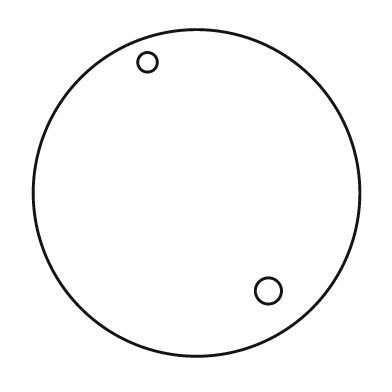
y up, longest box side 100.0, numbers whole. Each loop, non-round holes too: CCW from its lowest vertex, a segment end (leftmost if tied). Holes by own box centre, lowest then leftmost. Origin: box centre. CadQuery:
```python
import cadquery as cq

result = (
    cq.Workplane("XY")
    .moveTo(0.0, 0.0)
    .circle(50.0)
    .moveTo(22.0, -30.0)
    .circle(4.0)
    .moveTo(-15.0, 40.0)
    .circle(3.0)
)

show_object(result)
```